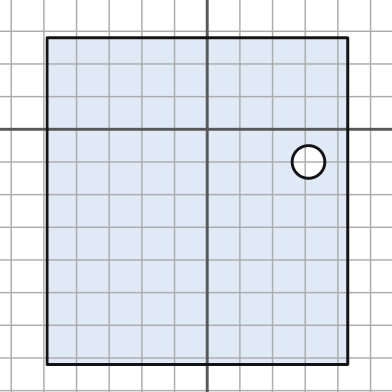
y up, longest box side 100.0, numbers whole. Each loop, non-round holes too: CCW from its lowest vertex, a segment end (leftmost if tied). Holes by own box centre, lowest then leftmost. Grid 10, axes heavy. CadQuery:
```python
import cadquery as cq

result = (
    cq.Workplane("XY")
    .moveTo(-49.0, -72.0)
    .lineTo(43.0, -72.0)
    .lineTo(43.0, 28.0)
    .lineTo(-49.0, 28.0)
    .close()
    .moveTo(31.0, -10.0)
    .circle(5.0)
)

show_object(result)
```